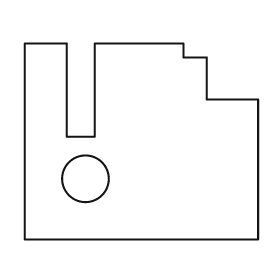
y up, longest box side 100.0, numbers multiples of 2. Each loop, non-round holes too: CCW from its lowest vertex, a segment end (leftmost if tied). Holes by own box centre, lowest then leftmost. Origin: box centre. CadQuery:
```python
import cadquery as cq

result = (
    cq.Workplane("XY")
    .moveTo(-50.0, -42.0)
    .lineTo(50.0, -42.0)
    .lineTo(50.0, 18.0)
    .lineTo(28.0, 18.0)
    .lineTo(28.0, 36.0)
    .lineTo(18.0, 36.0)
    .lineTo(18.0, 42.0)
    .lineTo(-20.0, 42.0)
    .lineTo(-20.0, 2.0)
    .lineTo(-32.0, 2.0)
    .lineTo(-32.0, 42.0)
    .lineTo(-50.0, 42.0)
    .close()
    .moveTo(-24.0, -16.0)
    .circle(10.0)
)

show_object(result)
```